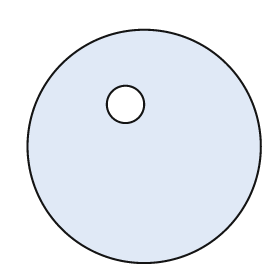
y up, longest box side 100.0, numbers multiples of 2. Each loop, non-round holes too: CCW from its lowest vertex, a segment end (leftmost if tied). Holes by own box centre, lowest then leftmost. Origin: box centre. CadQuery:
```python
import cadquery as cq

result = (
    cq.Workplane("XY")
    .moveTo(0.0, 0.0)
    .circle(50.0)
    .moveTo(-8.0, 18.0)
    .circle(8.0)
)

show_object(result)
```